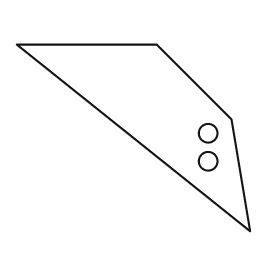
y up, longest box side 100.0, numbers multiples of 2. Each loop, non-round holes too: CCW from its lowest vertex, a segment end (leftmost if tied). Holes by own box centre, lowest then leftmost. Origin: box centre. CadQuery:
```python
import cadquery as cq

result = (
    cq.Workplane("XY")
    .moveTo(50.0, -40.0)
    .lineTo(42.0, 8.0)
    .lineTo(10.0, 40.0)
    .lineTo(-50.0, 40.0)
    .close()
    .moveTo(32.0, -10.0)
    .circle(4.0)
    .moveTo(32.0, 2.0)
    .circle(4.0)
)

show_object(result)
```